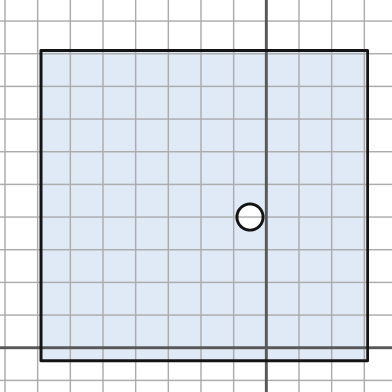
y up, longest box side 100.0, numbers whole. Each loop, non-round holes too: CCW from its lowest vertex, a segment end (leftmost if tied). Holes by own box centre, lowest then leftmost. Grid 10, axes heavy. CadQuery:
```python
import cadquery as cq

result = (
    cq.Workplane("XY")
    .moveTo(-69.0, -4.0)
    .lineTo(31.0, -4.0)
    .lineTo(31.0, 91.0)
    .lineTo(-69.0, 91.0)
    .close()
    .moveTo(-5.0, 40.0)
    .circle(4.0)
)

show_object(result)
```